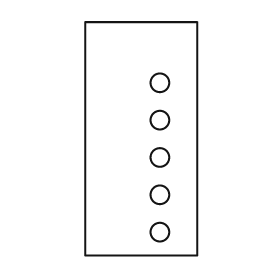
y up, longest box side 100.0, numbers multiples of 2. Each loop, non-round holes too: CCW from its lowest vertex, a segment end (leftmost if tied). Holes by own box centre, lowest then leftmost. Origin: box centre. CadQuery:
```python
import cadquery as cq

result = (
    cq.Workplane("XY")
    .moveTo(-24.0, -50.0)
    .lineTo(24.0, -50.0)
    .lineTo(24.0, 50.0)
    .lineTo(-24.0, 50.0)
    .close()
    .moveTo(8.0, -40.0)
    .circle(4.0)
    .moveTo(8.0, -24.0)
    .circle(4.0)
    .moveTo(8.0, -8.0)
    .circle(4.0)
    .moveTo(8.0, 8.0)
    .circle(4.0)
    .moveTo(8.0, 24.0)
    .circle(4.0)
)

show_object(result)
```